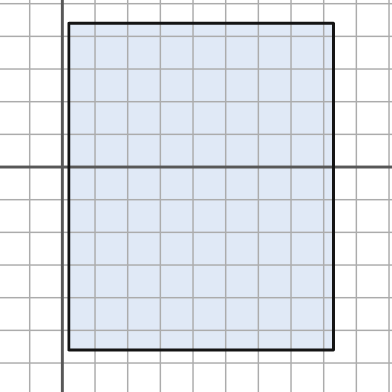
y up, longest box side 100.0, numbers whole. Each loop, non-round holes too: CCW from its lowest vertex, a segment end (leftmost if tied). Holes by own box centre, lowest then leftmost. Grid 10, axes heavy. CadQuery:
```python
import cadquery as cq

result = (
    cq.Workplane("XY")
    .moveTo(2.0, -56.0)
    .lineTo(83.0, -56.0)
    .lineTo(83.0, 44.0)
    .lineTo(2.0, 44.0)
    .close()
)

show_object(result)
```